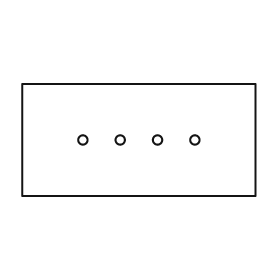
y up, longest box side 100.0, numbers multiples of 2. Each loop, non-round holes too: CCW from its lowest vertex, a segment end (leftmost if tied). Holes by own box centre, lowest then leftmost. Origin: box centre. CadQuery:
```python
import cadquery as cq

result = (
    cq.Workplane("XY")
    .moveTo(-50.0, -24.0)
    .lineTo(50.0, -24.0)
    .lineTo(50.0, 24.0)
    .lineTo(-50.0, 24.0)
    .close()
    .moveTo(-24.0, 0.0)
    .circle(2.0)
    .moveTo(-8.0, 0.0)
    .circle(2.0)
    .moveTo(8.0, 0.0)
    .circle(2.0)
    .moveTo(24.0, 0.0)
    .circle(2.0)
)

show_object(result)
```